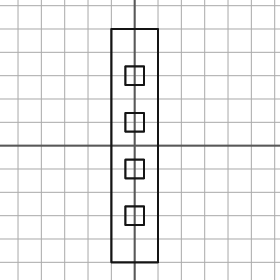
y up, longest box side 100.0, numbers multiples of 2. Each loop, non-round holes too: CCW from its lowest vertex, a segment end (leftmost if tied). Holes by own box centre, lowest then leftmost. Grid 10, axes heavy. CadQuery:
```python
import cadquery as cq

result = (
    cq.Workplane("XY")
    .moveTo(-10.0, -50.0)
    .lineTo(10.0, -50.0)
    .lineTo(10.0, 50.0)
    .lineTo(-10.0, 50.0)
    .close()
    .moveTo(-4.0, -34.0)
    .lineTo(4.0, -34.0)
    .lineTo(4.0, -26.0)
    .lineTo(-4.0, -26.0)
    .close()
    .moveTo(-4.0, -14.0)
    .lineTo(4.0, -14.0)
    .lineTo(4.0, -6.0)
    .lineTo(-4.0, -6.0)
    .close()
    .moveTo(-4.0, 6.0)
    .lineTo(4.0, 6.0)
    .lineTo(4.0, 14.0)
    .lineTo(-4.0, 14.0)
    .close()
    .moveTo(-4.0, 26.0)
    .lineTo(4.0, 26.0)
    .lineTo(4.0, 34.0)
    .lineTo(-4.0, 34.0)
    .close()
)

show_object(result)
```